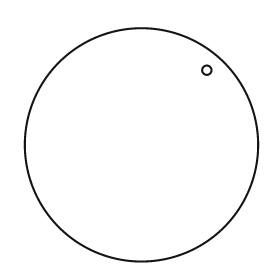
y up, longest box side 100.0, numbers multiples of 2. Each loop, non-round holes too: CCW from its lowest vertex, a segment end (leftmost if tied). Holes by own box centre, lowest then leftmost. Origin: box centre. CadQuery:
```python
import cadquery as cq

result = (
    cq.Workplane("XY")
    .moveTo(0.0, 0.0)
    .circle(50.0)
    .moveTo(28.0, 32.0)
    .circle(2.0)
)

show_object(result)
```